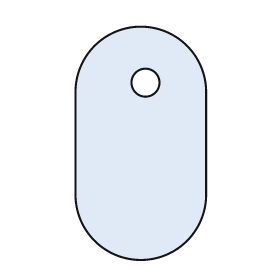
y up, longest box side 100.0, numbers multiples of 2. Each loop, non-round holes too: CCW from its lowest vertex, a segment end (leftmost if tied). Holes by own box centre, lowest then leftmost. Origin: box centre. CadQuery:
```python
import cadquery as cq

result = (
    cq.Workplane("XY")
    .moveTo(-28.0, -22.0)
    .threePointArc((0.0, -50.0), (28.0, -22.0))
    .lineTo(28.0, 22.0)
    .threePointArc((0.0, 50.0), (-28.0, 22.0))
    .close()
    .moveTo(2.0, 26.0)
    .circle(6.0)
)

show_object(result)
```